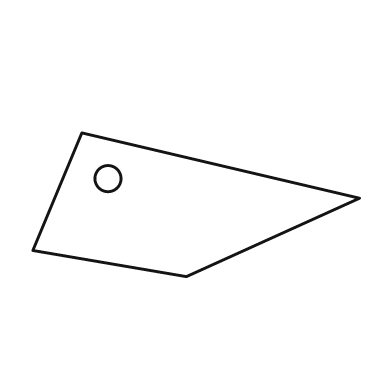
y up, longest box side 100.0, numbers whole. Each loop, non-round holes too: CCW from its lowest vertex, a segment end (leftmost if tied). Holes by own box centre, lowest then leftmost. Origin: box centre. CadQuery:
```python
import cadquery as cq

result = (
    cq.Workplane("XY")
    .moveTo(-3.0, -22.0)
    .lineTo(50.0, 2.0)
    .lineTo(-35.0, 22.0)
    .lineTo(-50.0, -14.0)
    .close()
    .moveTo(-27.0, 8.0)
    .circle(4.0)
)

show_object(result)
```